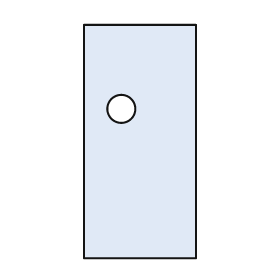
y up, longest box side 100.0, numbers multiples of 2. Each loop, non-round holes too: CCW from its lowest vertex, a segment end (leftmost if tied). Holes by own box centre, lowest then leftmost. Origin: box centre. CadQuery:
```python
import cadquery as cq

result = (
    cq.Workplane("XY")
    .moveTo(-24.0, -50.0)
    .lineTo(24.0, -50.0)
    .lineTo(24.0, 50.0)
    .lineTo(-24.0, 50.0)
    .close()
    .moveTo(-8.0, 14.0)
    .circle(6.0)
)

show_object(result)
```